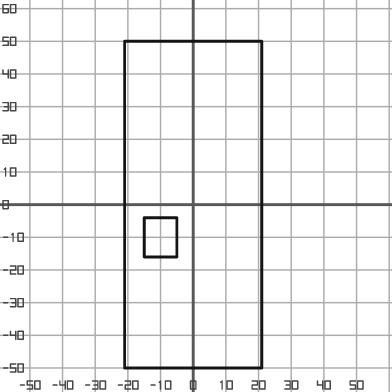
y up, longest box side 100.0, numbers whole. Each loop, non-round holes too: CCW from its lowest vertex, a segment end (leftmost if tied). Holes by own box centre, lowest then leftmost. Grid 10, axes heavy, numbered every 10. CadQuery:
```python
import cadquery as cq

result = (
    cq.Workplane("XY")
    .moveTo(-21.0, -50.0)
    .lineTo(21.0, -50.0)
    .lineTo(21.0, 50.0)
    .lineTo(-21.0, 50.0)
    .close()
    .moveTo(-15.0, -16.0)
    .lineTo(-5.0, -16.0)
    .lineTo(-5.0, -4.0)
    .lineTo(-15.0, -4.0)
    .close()
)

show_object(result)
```